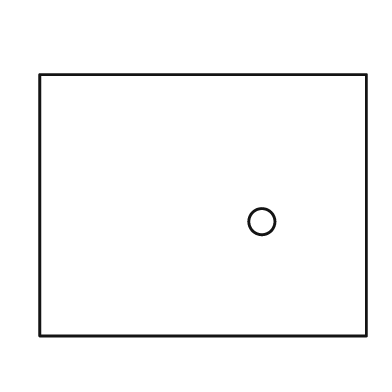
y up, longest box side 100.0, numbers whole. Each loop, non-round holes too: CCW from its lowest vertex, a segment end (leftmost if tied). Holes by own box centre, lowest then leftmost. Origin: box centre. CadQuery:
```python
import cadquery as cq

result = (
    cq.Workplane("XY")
    .moveTo(-50.0, -40.0)
    .lineTo(50.0, -40.0)
    .lineTo(50.0, 40.0)
    .lineTo(-50.0, 40.0)
    .close()
    .moveTo(18.0, -5.0)
    .circle(4.0)
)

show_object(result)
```